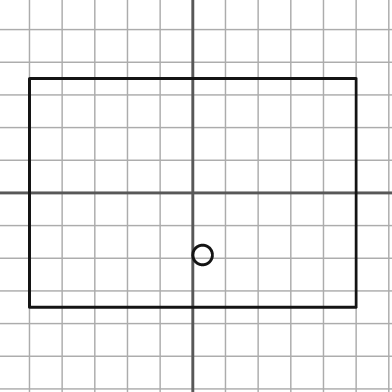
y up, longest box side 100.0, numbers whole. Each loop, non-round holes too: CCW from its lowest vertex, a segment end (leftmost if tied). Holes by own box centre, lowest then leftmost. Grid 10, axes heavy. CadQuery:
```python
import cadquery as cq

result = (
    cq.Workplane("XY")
    .moveTo(-50.0, -35.0)
    .lineTo(50.0, -35.0)
    .lineTo(50.0, 35.0)
    .lineTo(-50.0, 35.0)
    .close()
    .moveTo(3.0, -19.0)
    .circle(3.0)
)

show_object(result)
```